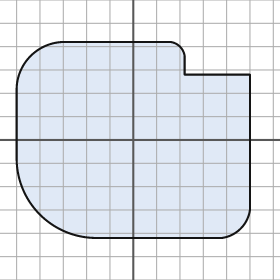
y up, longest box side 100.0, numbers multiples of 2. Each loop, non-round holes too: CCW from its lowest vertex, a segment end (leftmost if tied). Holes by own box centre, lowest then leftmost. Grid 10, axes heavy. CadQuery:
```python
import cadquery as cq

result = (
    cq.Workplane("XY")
    .moveTo(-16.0, -42.0)
    .lineTo(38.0, -42.0)
    .threePointArc((46.0, -38.0), (50.0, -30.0))
    .lineTo(50.0, 28.0)
    .lineTo(22.0, 28.0)
    .lineTo(22.0, 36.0)
    .threePointArc((20.0, 40.0), (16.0, 42.0))
    .lineTo(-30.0, 42.0)
    .threePointArc((-44.0, 36.0), (-50.0, 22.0))
    .lineTo(-50.0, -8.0)
    .threePointArc((-40.0, -32.0), (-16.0, -42.0))
    .close()
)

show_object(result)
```